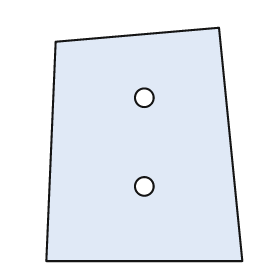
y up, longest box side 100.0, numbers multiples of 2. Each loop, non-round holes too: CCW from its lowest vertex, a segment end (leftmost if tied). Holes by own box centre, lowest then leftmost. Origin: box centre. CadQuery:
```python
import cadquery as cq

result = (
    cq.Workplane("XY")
    .moveTo(-42.0, -50.0)
    .lineTo(42.0, -50.0)
    .lineTo(32.0, 50.0)
    .lineTo(-38.0, 44.0)
    .close()
    .moveTo(0.0, -18.0)
    .circle(4.0)
    .moveTo(0.0, 20.0)
    .circle(4.0)
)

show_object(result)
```